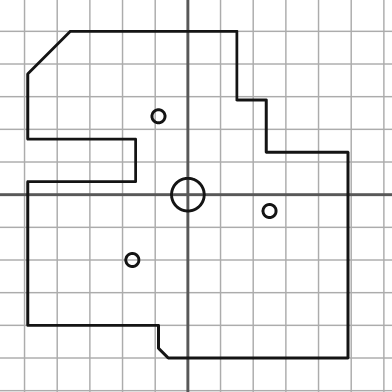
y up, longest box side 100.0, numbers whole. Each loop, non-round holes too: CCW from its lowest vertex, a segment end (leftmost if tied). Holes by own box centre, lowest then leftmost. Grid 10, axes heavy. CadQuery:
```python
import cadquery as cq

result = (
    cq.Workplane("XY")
    .moveTo(-6.0, -50.0)
    .lineTo(49.0, -50.0)
    .lineTo(49.0, 13.0)
    .lineTo(24.0, 13.0)
    .lineTo(24.0, 29.0)
    .lineTo(15.0, 29.0)
    .lineTo(15.0, 50.0)
    .lineTo(-36.0, 50.0)
    .lineTo(-49.0, 37.0)
    .lineTo(-49.0, 17.0)
    .lineTo(-16.0, 17.0)
    .lineTo(-16.0, 4.0)
    .lineTo(-49.0, 4.0)
    .lineTo(-49.0, -40.0)
    .lineTo(-9.0, -40.0)
    .lineTo(-9.0, -47.0)
    .close()
    .moveTo(-17.0, -20.0)
    .circle(2.0)
    .moveTo(25.0, -5.0)
    .circle(2.0)
    .moveTo(0.0, 0.0)
    .circle(5.0)
    .moveTo(-9.0, 24.0)
    .circle(2.0)
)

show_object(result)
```